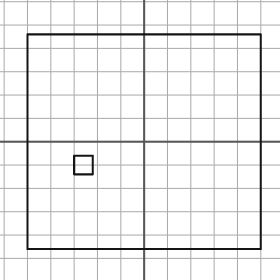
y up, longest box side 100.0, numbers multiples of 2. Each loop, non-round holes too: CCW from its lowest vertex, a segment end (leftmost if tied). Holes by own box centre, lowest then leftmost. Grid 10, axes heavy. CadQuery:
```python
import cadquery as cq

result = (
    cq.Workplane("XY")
    .moveTo(-50.0, -46.0)
    .lineTo(50.0, -46.0)
    .lineTo(50.0, 46.0)
    .lineTo(-50.0, 46.0)
    .close()
    .moveTo(-30.0, -14.0)
    .lineTo(-22.0, -14.0)
    .lineTo(-22.0, -6.0)
    .lineTo(-30.0, -6.0)
    .close()
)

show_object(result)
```